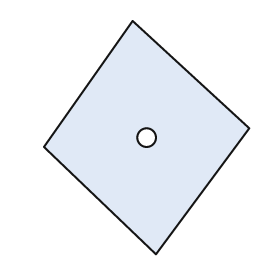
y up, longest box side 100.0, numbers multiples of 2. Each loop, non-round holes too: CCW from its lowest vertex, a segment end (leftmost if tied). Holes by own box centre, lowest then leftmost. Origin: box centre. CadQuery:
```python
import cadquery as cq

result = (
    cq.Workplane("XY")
    .moveTo(4.0, -50.0)
    .lineTo(44.0, 4.0)
    .lineTo(-6.0, 50.0)
    .lineTo(-44.0, -4.0)
    .close()
    .moveTo(0.0, 0.0)
    .circle(4.0)
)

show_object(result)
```